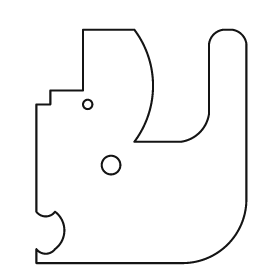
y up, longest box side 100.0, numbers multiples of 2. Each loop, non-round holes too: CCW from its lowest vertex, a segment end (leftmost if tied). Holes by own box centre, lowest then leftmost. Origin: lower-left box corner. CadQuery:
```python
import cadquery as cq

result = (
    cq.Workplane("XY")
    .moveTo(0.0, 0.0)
    .lineTo(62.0, 0.0)
    .threePointArc((82.0, 8.0), (90.0, 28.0))
    .lineTo(90.0, 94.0)
    .threePointArc((88.0, 98.0), (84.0, 100.0))
    .lineTo(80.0, 100.0)
    .threePointArc((76.0, 98.0), (74.0, 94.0))
    .lineTo(74.0, 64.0)
    .threePointArc((70.0, 56.0), (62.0, 52.0))
    .lineTo(42.0, 52.0)
    .threePointArc((50.0, 76.0), (42.0, 100.0))
    .lineTo(20.0, 100.0)
    .lineTo(20.0, 74.0)
    .lineTo(6.0, 74.0)
    .lineTo(6.0, 68.0)
    .lineTo(0.0, 68.0)
    .lineTo(0.0, 22.0)
    .threePointArc((4.0, 20.0), (8.0, 22.0))
    .threePointArc((12.0, 14.0), (8.0, 6.0))
    .threePointArc((4.0, 4.0), (0.0, 6.0))
    .close()
    .moveTo(32.0, 42.0)
    .circle(4.0)
    .moveTo(22.0, 68.0)
    .circle(2.0)
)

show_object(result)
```